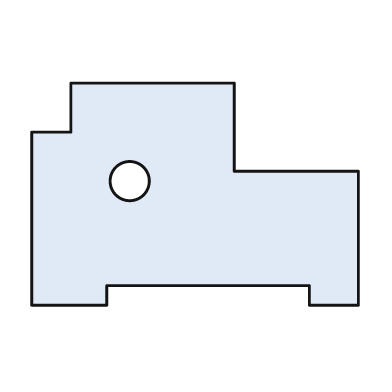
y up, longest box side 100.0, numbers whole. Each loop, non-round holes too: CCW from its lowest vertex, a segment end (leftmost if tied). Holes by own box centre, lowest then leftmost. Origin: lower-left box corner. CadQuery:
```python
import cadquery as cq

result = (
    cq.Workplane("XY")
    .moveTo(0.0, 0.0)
    .lineTo(23.0, 0.0)
    .lineTo(23.0, 6.0)
    .lineTo(85.0, 6.0)
    .lineTo(85.0, 0.0)
    .lineTo(100.0, 0.0)
    .lineTo(100.0, 41.0)
    .lineTo(62.0, 41.0)
    .lineTo(62.0, 68.0)
    .lineTo(12.0, 68.0)
    .lineTo(12.0, 53.0)
    .lineTo(0.0, 53.0)
    .close()
    .moveTo(30.0, 38.0)
    .circle(6.0)
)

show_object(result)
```